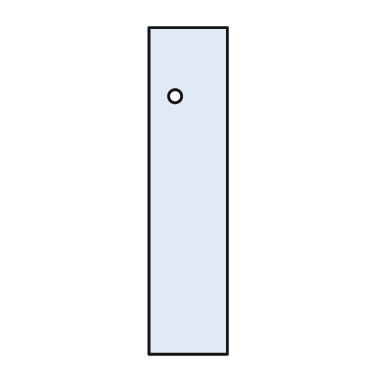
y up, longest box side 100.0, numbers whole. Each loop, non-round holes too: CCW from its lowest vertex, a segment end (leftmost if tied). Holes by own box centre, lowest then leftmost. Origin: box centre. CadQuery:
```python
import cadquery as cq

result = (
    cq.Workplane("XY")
    .moveTo(-12.0, -50.0)
    .lineTo(12.0, -50.0)
    .lineTo(12.0, 50.0)
    .lineTo(-12.0, 50.0)
    .close()
    .moveTo(-4.0, 29.0)
    .circle(2.0)
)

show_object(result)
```